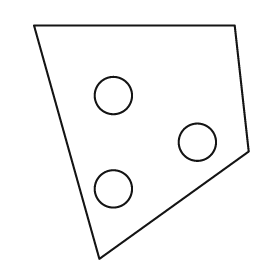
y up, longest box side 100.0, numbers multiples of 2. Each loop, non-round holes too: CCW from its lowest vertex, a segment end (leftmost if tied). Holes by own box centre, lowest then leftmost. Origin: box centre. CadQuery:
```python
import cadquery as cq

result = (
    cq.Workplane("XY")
    .moveTo(-18.0, -50.0)
    .lineTo(46.0, -4.0)
    .lineTo(40.0, 50.0)
    .lineTo(-46.0, 50.0)
    .close()
    .moveTo(-12.0, -20.0)
    .circle(8.0)
    .moveTo(24.0, 0.0)
    .circle(8.0)
    .moveTo(-12.0, 20.0)
    .circle(8.0)
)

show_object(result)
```